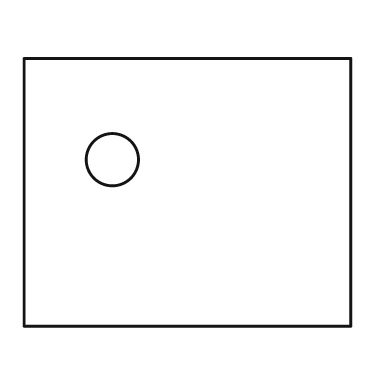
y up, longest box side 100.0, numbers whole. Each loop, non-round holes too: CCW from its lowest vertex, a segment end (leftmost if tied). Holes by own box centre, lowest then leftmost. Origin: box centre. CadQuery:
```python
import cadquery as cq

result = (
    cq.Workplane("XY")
    .moveTo(-50.0, -41.0)
    .lineTo(50.0, -41.0)
    .lineTo(50.0, 41.0)
    .lineTo(-50.0, 41.0)
    .close()
    .moveTo(-23.0, 10.0)
    .circle(8.0)
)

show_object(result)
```